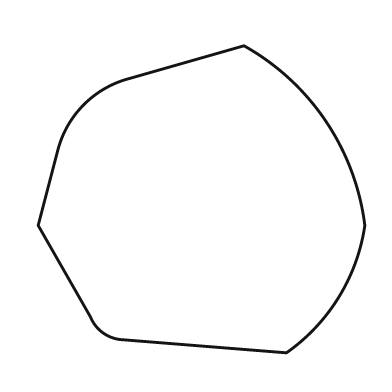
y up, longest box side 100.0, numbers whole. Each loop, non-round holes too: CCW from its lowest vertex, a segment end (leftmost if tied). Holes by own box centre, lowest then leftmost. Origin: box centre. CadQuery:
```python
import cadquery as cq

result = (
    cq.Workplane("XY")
    .moveTo(26.0, -47.0)
    .threePointArc((42.0, -30.0), (50.0, -8.0))
    .threePointArc((38.0, 24.0), (13.0, 47.0))
    .lineTo(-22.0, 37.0)
    .threePointArc((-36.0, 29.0), (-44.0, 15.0))
    .lineTo(-50.0, -8.0)
    .lineTo(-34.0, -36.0)
    .threePointArc((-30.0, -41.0), (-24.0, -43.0))
    .close()
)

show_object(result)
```